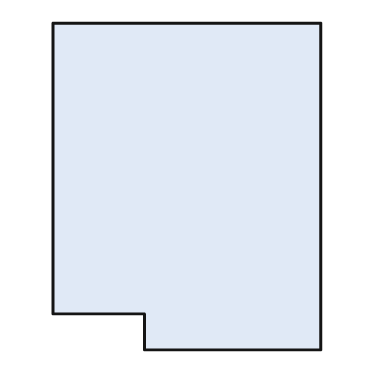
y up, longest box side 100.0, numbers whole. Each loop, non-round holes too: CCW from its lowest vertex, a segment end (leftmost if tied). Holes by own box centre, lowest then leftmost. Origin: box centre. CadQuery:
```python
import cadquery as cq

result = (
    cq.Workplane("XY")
    .moveTo(-13.0, -50.0)
    .lineTo(41.0, -50.0)
    .lineTo(41.0, 50.0)
    .lineTo(-41.0, 50.0)
    .lineTo(-41.0, -39.0)
    .lineTo(-13.0, -39.0)
    .close()
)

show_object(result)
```